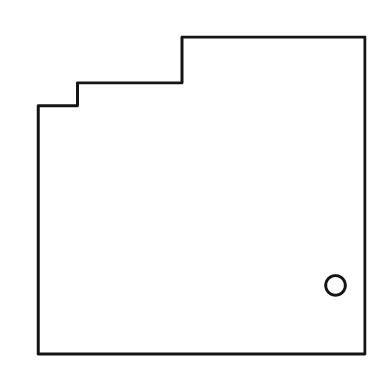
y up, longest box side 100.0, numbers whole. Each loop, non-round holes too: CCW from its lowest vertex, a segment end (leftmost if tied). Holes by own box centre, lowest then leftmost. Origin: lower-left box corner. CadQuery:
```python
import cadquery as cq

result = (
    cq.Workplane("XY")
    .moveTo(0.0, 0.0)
    .lineTo(100.0, 0.0)
    .lineTo(100.0, 97.0)
    .lineTo(44.0, 97.0)
    .lineTo(44.0, 83.0)
    .lineTo(12.0, 83.0)
    .lineTo(12.0, 76.0)
    .lineTo(0.0, 76.0)
    .close()
    .moveTo(91.0, 21.0)
    .circle(3.0)
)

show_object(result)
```